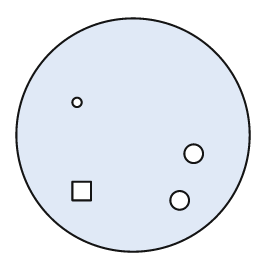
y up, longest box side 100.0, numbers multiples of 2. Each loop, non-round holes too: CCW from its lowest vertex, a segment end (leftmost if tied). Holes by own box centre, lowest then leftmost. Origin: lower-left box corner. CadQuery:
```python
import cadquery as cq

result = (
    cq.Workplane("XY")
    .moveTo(50.0, 50.0)
    .circle(50.0)
    .moveTo(70.0, 22.0)
    .circle(4.0)
    .moveTo(24.0, 22.0)
    .lineTo(32.0, 22.0)
    .lineTo(32.0, 30.0)
    .lineTo(24.0, 30.0)
    .close()
    .moveTo(76.0, 42.0)
    .circle(4.0)
    .moveTo(26.0, 64.0)
    .circle(2.0)
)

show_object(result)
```